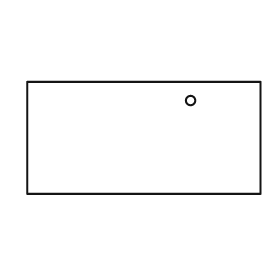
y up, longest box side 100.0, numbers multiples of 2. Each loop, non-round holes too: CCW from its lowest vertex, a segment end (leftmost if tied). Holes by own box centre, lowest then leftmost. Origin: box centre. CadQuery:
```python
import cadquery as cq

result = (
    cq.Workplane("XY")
    .moveTo(-50.0, -24.0)
    .lineTo(50.0, -24.0)
    .lineTo(50.0, 24.0)
    .lineTo(-50.0, 24.0)
    .close()
    .moveTo(20.0, 16.0)
    .circle(2.0)
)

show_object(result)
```